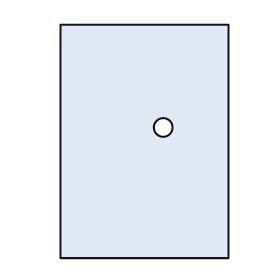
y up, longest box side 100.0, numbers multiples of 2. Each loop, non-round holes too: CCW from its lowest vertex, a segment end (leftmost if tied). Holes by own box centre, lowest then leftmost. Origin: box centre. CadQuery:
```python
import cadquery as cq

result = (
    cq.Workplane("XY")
    .moveTo(-36.0, -50.0)
    .lineTo(36.0, -50.0)
    .lineTo(36.0, 50.0)
    .lineTo(-36.0, 50.0)
    .close()
    .moveTo(8.0, 6.0)
    .circle(4.0)
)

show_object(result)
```